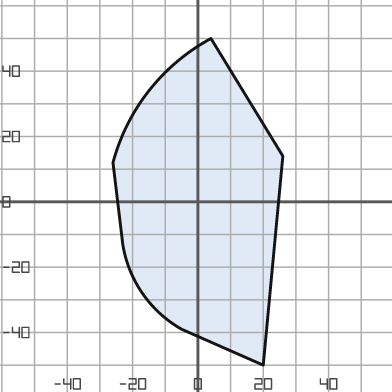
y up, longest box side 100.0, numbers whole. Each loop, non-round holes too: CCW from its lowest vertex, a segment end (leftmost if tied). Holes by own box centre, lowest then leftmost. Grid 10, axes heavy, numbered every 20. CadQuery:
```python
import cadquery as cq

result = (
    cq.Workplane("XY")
    .moveTo(20.0, -50.0)
    .lineTo(26.0, 14.0)
    .lineTo(4.0, 50.0)
    .threePointArc((-15.0, 34.0), (-26.0, 12.0))
    .lineTo(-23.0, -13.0)
    .threePointArc((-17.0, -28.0), (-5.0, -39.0))
    .close()
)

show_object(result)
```